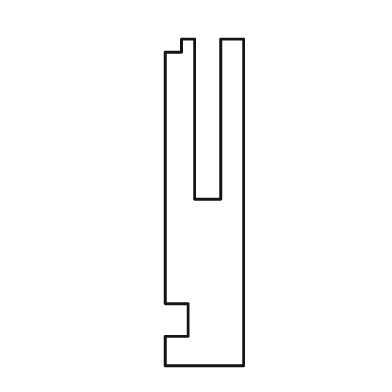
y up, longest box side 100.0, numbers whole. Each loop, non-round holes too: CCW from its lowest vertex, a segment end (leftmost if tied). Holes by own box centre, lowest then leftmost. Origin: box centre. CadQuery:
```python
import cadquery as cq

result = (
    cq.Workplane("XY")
    .moveTo(-12.0, -50.0)
    .lineTo(12.0, -50.0)
    .lineTo(12.0, 50.0)
    .lineTo(5.0, 50.0)
    .lineTo(5.0, 1.0)
    .lineTo(-3.0, 1.0)
    .lineTo(-3.0, 50.0)
    .lineTo(-7.0, 50.0)
    .lineTo(-7.0, 46.0)
    .lineTo(-12.0, 46.0)
    .lineTo(-12.0, -31.0)
    .lineTo(-5.0, -31.0)
    .lineTo(-5.0, -41.0)
    .lineTo(-12.0, -41.0)
    .close()
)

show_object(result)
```